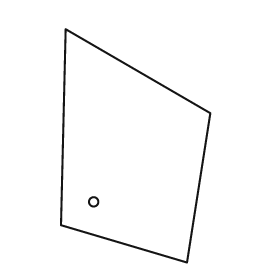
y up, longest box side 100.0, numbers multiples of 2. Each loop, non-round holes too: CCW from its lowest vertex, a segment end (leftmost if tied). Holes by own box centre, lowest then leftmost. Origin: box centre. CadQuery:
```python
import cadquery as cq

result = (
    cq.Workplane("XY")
    .moveTo(22.0, -50.0)
    .lineTo(32.0, 14.0)
    .lineTo(-30.0, 50.0)
    .lineTo(-32.0, -34.0)
    .close()
    .moveTo(-18.0, -24.0)
    .circle(2.0)
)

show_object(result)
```